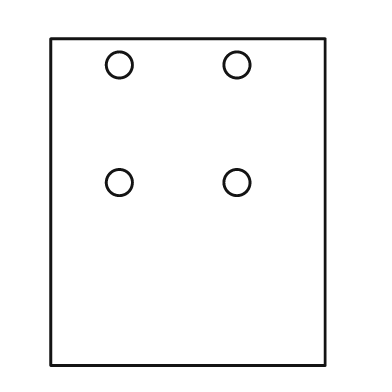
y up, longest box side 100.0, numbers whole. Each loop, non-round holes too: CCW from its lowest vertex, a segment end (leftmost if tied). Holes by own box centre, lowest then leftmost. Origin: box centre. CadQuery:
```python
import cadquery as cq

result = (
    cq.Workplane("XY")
    .moveTo(-42.0, -50.0)
    .lineTo(42.0, -50.0)
    .lineTo(42.0, 50.0)
    .lineTo(-42.0, 50.0)
    .close()
    .moveTo(-21.0, 6.0)
    .circle(4.0)
    .moveTo(15.0, 6.0)
    .circle(4.0)
    .moveTo(-21.0, 42.0)
    .circle(4.0)
    .moveTo(15.0, 42.0)
    .circle(4.0)
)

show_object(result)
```